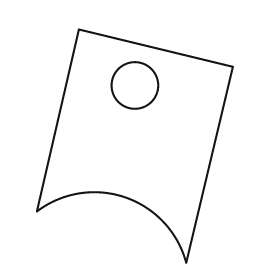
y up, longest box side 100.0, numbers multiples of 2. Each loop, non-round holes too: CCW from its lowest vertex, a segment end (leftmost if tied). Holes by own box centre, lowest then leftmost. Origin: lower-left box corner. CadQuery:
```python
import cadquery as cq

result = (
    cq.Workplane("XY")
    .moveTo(64.0, 0.0)
    .lineTo(84.0, 84.0)
    .lineTo(18.0, 100.0)
    .lineTo(0.0, 22.0)
    .threePointArc((38.0, 28.0), (64.0, 0.0))
    .close()
    .moveTo(42.0, 76.0)
    .circle(10.0)
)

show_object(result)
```